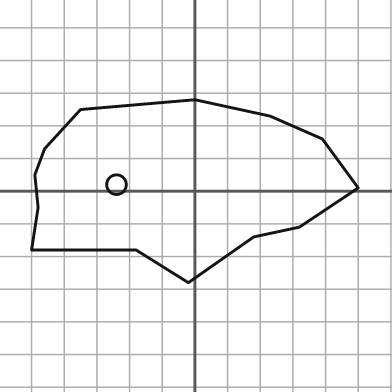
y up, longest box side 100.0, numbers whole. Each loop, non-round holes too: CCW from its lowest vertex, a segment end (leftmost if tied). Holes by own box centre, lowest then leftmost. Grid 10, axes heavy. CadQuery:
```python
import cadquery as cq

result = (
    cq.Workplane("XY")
    .moveTo(-2.0, -28.0)
    .lineTo(18.0, -14.0)
    .lineTo(32.0, -11.0)
    .lineTo(50.0, 1.0)
    .lineTo(39.0, 16.0)
    .lineTo(23.0, 23.0)
    .lineTo(0.0, 28.0)
    .lineTo(-35.0, 25.0)
    .lineTo(-46.0, 13.0)
    .lineTo(-49.0, 5.0)
    .lineTo(-48.0, -5.0)
    .lineTo(-50.0, -18.0)
    .lineTo(-18.0, -18.0)
    .close()
    .moveTo(-24.0, 2.0)
    .circle(3.0)
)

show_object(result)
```